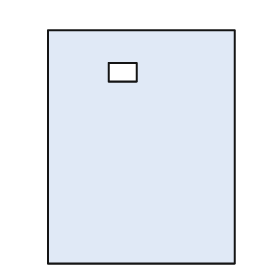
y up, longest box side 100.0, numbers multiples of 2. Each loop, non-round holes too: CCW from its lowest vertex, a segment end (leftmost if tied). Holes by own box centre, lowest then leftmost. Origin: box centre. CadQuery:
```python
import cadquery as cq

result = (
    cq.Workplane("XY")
    .moveTo(-40.0, -50.0)
    .lineTo(40.0, -50.0)
    .lineTo(40.0, 50.0)
    .lineTo(-40.0, 50.0)
    .close()
    .moveTo(-14.0, 28.0)
    .lineTo(-2.0, 28.0)
    .lineTo(-2.0, 36.0)
    .lineTo(-14.0, 36.0)
    .close()
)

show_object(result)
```